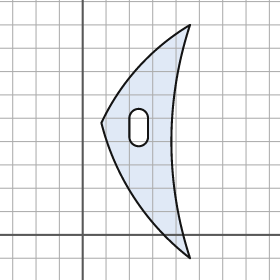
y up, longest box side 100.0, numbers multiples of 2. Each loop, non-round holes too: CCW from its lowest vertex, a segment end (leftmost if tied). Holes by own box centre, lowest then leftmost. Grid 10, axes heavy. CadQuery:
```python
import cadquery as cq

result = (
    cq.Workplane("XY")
    .moveTo(46.0, -10.0)
    .threePointArc((38.0, 40.0), (46.0, 90.0))
    .threePointArc((24.0, 72.0), (8.0, 48.0))
    .threePointArc((22.0, 16.0), (46.0, -10.0))
    .close()
    .moveTo(20.0, 42.0)
    .threePointArc((24.0, 38.0), (28.0, 42.0))
    .lineTo(28.0, 50.0)
    .threePointArc((24.0, 54.0), (20.0, 50.0))
    .close()
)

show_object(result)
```